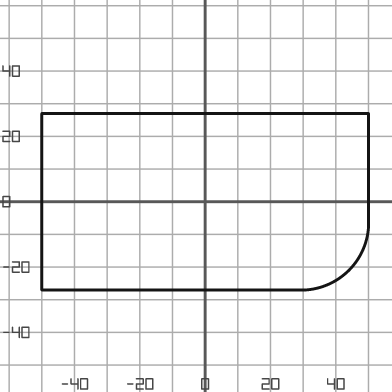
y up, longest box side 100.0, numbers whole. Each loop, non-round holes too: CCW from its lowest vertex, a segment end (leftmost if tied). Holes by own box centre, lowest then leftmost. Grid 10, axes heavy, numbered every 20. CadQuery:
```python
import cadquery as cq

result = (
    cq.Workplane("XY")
    .moveTo(-50.0, -27.0)
    .lineTo(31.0, -27.0)
    .threePointArc((44.0, -21.0), (50.0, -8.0))
    .lineTo(50.0, 27.0)
    .lineTo(-50.0, 27.0)
    .close()
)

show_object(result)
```